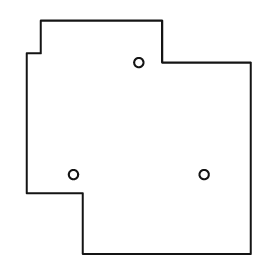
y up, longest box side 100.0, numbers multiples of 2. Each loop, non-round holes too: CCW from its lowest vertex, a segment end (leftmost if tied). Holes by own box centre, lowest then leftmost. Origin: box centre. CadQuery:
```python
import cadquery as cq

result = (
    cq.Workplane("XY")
    .moveTo(-24.0, -50.0)
    .lineTo(48.0, -50.0)
    .lineTo(48.0, 32.0)
    .lineTo(10.0, 32.0)
    .lineTo(10.0, 50.0)
    .lineTo(-42.0, 50.0)
    .lineTo(-42.0, 36.0)
    .lineTo(-48.0, 36.0)
    .lineTo(-48.0, -24.0)
    .lineTo(-24.0, -24.0)
    .close()
    .moveTo(-28.0, -16.0)
    .circle(2.0)
    .moveTo(28.0, -16.0)
    .circle(2.0)
    .moveTo(0.0, 32.0)
    .circle(2.0)
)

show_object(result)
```